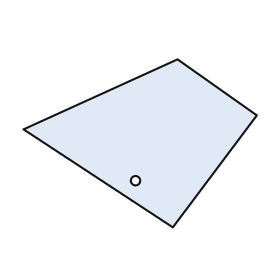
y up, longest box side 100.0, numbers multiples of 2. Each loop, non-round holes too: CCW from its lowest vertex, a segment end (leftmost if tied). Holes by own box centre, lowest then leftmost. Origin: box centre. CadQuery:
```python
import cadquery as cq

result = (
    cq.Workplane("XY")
    .moveTo(14.0, -36.0)
    .lineTo(50.0, 12.0)
    .lineTo(16.0, 36.0)
    .lineTo(-50.0, 6.0)
    .close()
    .moveTo(-2.0, -16.0)
    .circle(2.0)
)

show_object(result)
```